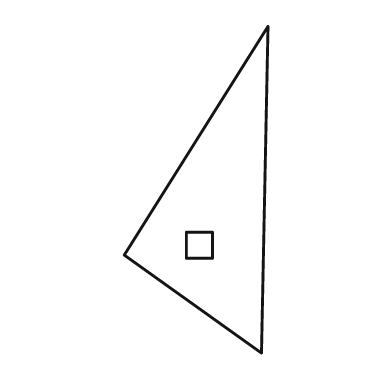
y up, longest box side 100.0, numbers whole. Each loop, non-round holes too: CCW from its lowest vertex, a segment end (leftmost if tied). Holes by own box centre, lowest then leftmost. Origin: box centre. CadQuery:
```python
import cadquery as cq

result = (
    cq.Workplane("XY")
    .moveTo(20.0, -50.0)
    .lineTo(22.0, 50.0)
    .lineTo(-22.0, -20.0)
    .close()
    .moveTo(-3.0, -21.0)
    .lineTo(5.0, -21.0)
    .lineTo(5.0, -13.0)
    .lineTo(-3.0, -13.0)
    .close()
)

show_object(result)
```